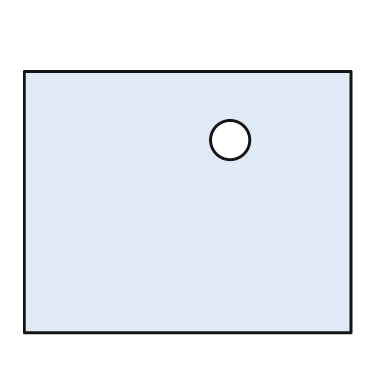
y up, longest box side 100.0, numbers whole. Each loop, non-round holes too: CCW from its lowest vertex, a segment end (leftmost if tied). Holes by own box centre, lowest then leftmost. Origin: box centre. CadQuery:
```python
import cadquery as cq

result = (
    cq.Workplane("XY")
    .moveTo(-50.0, -40.0)
    .lineTo(50.0, -40.0)
    .lineTo(50.0, 40.0)
    .lineTo(-50.0, 40.0)
    .close()
    .moveTo(13.0, 19.0)
    .circle(6.0)
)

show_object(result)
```